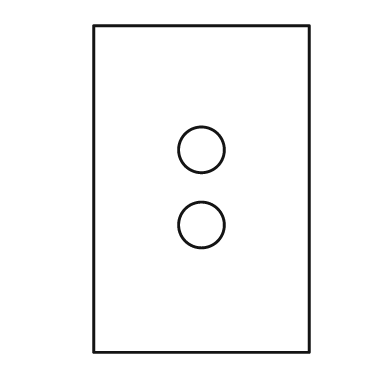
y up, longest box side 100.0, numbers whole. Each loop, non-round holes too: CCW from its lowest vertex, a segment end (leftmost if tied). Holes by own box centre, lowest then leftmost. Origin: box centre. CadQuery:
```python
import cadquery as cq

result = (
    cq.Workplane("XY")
    .moveTo(-33.0, -50.0)
    .lineTo(33.0, -50.0)
    .lineTo(33.0, 50.0)
    .lineTo(-33.0, 50.0)
    .close()
    .moveTo(0.0, -11.0)
    .circle(7.0)
    .moveTo(0.0, 12.0)
    .circle(7.0)
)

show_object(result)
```